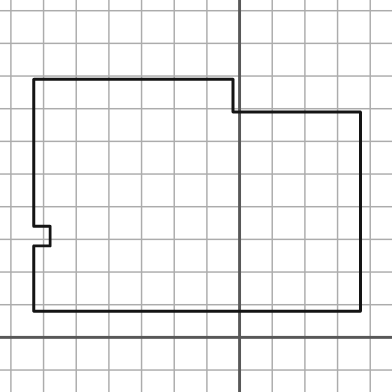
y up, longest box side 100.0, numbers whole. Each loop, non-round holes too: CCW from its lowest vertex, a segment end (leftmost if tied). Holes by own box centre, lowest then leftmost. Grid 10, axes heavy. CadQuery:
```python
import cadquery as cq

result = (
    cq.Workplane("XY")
    .moveTo(-63.0, 8.0)
    .lineTo(37.0, 8.0)
    .lineTo(37.0, 69.0)
    .lineTo(-2.0, 69.0)
    .lineTo(-2.0, 79.0)
    .lineTo(-63.0, 79.0)
    .lineTo(-63.0, 34.0)
    .lineTo(-58.0, 34.0)
    .lineTo(-58.0, 28.0)
    .lineTo(-63.0, 28.0)
    .close()
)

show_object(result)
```